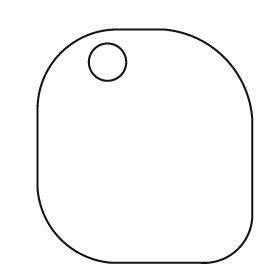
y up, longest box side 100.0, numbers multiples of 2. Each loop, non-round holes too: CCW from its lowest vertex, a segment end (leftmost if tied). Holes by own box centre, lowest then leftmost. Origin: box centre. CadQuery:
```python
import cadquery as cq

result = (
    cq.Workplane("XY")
    .moveTo(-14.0, -50.0)
    .lineTo(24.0, -50.0)
    .threePointArc((40.0, -44.0), (46.0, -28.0))
    .lineTo(46.0, 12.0)
    .threePointArc((34.0, 38.0), (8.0, 50.0))
    .lineTo(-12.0, 50.0)
    .threePointArc((-36.0, 40.0), (-46.0, 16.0))
    .lineTo(-46.0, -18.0)
    .threePointArc((-36.0, -40.0), (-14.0, -50.0))
    .close()
    .moveTo(-16.0, 36.0)
    .circle(8.0)
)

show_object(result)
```